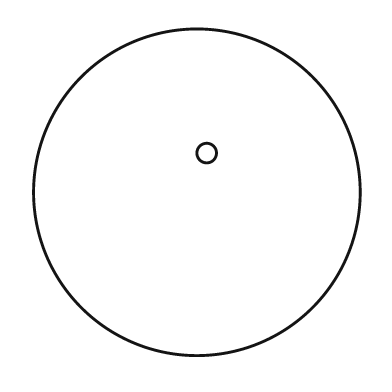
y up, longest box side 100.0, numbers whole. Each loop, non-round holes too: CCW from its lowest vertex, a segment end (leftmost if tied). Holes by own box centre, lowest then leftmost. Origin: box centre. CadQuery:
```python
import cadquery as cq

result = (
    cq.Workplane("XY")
    .moveTo(0.0, 0.0)
    .circle(50.0)
    .moveTo(3.0, 12.0)
    .circle(3.0)
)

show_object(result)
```